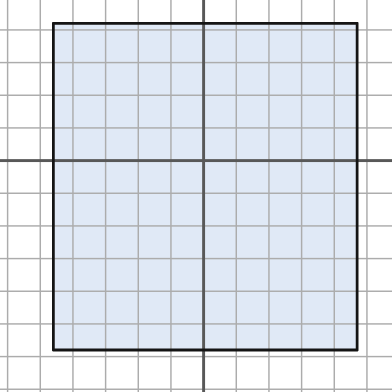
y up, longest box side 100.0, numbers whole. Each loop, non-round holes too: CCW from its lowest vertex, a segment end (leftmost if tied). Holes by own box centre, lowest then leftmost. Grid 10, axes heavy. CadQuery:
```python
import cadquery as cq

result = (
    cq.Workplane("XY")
    .moveTo(-46.0, -58.0)
    .lineTo(47.0, -58.0)
    .lineTo(47.0, 42.0)
    .lineTo(-46.0, 42.0)
    .close()
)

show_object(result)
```